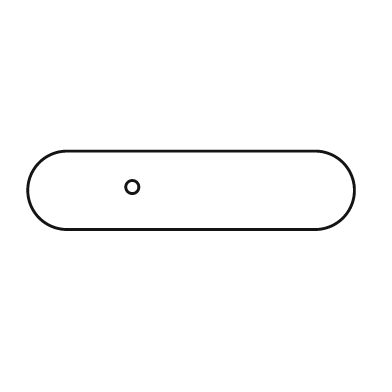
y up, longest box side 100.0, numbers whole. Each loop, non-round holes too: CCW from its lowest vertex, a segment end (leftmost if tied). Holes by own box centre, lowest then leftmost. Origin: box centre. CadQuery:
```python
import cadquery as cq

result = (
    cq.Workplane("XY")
    .moveTo(-38.0, -12.0)
    .lineTo(38.0, -12.0)
    .threePointArc((50.0, 0.0), (38.0, 12.0))
    .lineTo(-38.0, 12.0)
    .threePointArc((-50.0, 0.0), (-38.0, -12.0))
    .close()
    .moveTo(-18.0, 1.0)
    .circle(2.0)
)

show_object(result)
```